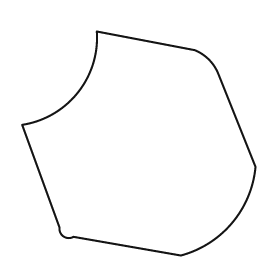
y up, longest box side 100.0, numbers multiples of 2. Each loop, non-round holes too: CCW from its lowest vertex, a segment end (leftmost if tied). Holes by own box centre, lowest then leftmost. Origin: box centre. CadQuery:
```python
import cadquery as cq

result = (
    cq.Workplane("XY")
    .moveTo(18.0, -48.0)
    .threePointArc((40.0, -34.0), (50.0, -10.0))
    .lineTo(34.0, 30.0)
    .threePointArc((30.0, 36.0), (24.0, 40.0))
    .lineTo(-18.0, 48.0)
    .threePointArc((-26.0, 22.0), (-50.0, 8.0))
    .lineTo(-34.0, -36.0)
    .threePointArc((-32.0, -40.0), (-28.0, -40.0))
    .close()
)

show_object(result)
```